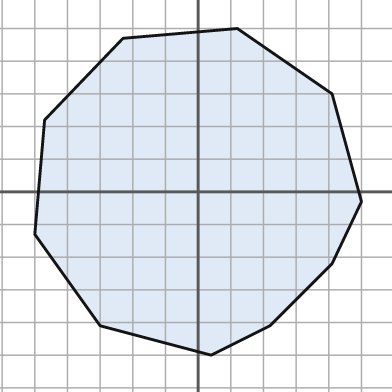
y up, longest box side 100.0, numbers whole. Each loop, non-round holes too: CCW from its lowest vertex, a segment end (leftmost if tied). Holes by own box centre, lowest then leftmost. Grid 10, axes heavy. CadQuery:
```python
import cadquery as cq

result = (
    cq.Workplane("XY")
    .moveTo(4.0, -50.0)
    .lineTo(22.0, -41.0)
    .lineTo(41.0, -22.0)
    .lineTo(50.0, -3.0)
    .lineTo(41.0, 30.0)
    .lineTo(12.0, 50.0)
    .lineTo(-23.0, 47.0)
    .lineTo(-47.0, 22.0)
    .lineTo(-50.0, -13.0)
    .lineTo(-30.0, -41.0)
    .close()
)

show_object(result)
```